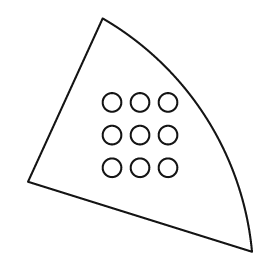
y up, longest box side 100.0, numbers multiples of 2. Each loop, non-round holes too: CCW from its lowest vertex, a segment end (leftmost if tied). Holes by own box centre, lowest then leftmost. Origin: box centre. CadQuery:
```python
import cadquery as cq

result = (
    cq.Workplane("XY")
    .moveTo(48.0, -50.0)
    .threePointArc((28.0, 8.0), (-16.0, 50.0))
    .lineTo(-48.0, -20.0)
    .close()
    .moveTo(-12.0, -14.0)
    .circle(4.0)
    .moveTo(0.0, -14.0)
    .circle(4.0)
    .moveTo(12.0, -14.0)
    .circle(4.0)
    .moveTo(-12.0, 0.0)
    .circle(4.0)
    .moveTo(0.0, 0.0)
    .circle(4.0)
    .moveTo(12.0, 0.0)
    .circle(4.0)
    .moveTo(-12.0, 14.0)
    .circle(4.0)
    .moveTo(0.0, 14.0)
    .circle(4.0)
    .moveTo(12.0, 14.0)
    .circle(4.0)
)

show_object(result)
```